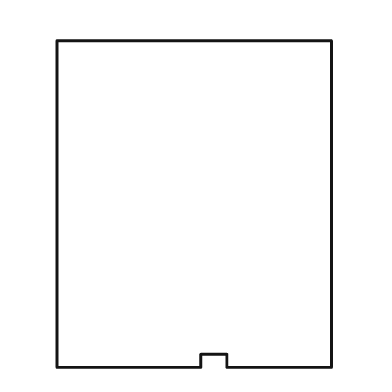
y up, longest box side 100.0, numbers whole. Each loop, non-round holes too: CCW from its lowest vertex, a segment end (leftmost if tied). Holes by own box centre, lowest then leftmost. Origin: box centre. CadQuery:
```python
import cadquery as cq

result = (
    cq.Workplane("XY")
    .moveTo(-42.0, -50.0)
    .lineTo(2.0, -50.0)
    .lineTo(2.0, -46.0)
    .lineTo(10.0, -46.0)
    .lineTo(10.0, -50.0)
    .lineTo(42.0, -50.0)
    .lineTo(42.0, 50.0)
    .lineTo(-42.0, 50.0)
    .close()
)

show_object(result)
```